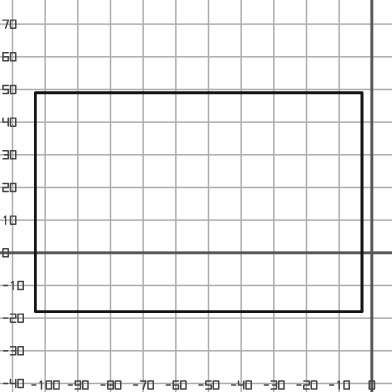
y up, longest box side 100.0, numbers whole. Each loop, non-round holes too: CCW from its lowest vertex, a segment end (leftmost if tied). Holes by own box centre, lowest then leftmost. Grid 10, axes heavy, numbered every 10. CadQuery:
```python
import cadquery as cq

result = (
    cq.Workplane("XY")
    .moveTo(-103.0, -18.0)
    .lineTo(-3.0, -18.0)
    .lineTo(-3.0, 49.0)
    .lineTo(-103.0, 49.0)
    .close()
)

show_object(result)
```